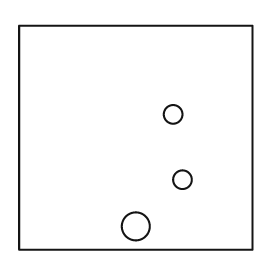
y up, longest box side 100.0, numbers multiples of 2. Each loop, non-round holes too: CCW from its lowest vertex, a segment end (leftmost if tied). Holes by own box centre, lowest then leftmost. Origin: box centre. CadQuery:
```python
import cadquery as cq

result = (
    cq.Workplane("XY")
    .moveTo(-50.0, -48.0)
    .lineTo(50.0, -48.0)
    .lineTo(50.0, 48.0)
    .lineTo(-50.0, 48.0)
    .close()
    .moveTo(0.0, -38.0)
    .circle(6.0)
    .moveTo(20.0, -18.0)
    .circle(4.0)
    .moveTo(16.0, 10.0)
    .circle(4.0)
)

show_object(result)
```